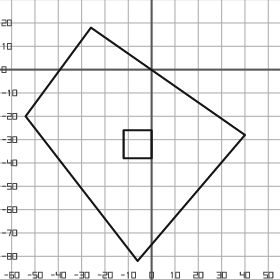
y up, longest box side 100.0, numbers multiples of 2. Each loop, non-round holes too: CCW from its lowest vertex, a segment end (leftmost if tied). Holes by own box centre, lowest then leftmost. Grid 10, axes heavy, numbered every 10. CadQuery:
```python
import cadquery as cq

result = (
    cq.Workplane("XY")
    .moveTo(-6.0, -82.0)
    .lineTo(40.0, -28.0)
    .lineTo(-26.0, 18.0)
    .lineTo(-54.0, -20.0)
    .close()
    .moveTo(-12.0, -38.0)
    .lineTo(0.0, -38.0)
    .lineTo(0.0, -26.0)
    .lineTo(-12.0, -26.0)
    .close()
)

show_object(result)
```